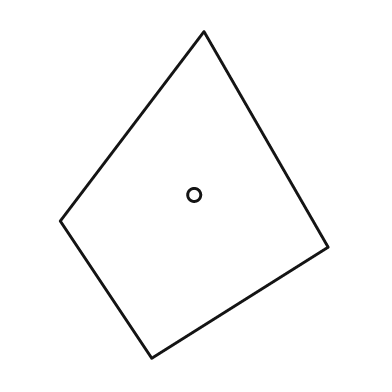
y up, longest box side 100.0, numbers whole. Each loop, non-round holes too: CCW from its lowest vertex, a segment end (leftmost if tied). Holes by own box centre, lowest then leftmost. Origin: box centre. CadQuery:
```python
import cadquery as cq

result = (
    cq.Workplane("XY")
    .moveTo(-13.0, -50.0)
    .lineTo(41.0, -16.0)
    .lineTo(3.0, 50.0)
    .lineTo(-41.0, -8.0)
    .close()
    .moveTo(0.0, 0.0)
    .circle(2.0)
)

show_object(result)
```